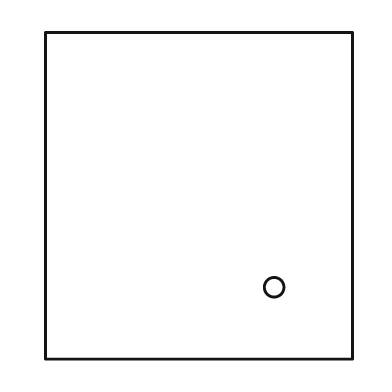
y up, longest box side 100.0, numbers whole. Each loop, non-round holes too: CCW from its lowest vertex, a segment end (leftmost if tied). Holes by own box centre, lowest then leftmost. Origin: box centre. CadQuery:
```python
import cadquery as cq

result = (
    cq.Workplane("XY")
    .moveTo(-47.0, -50.0)
    .lineTo(47.0, -50.0)
    .lineTo(47.0, 50.0)
    .lineTo(-47.0, 50.0)
    .close()
    .moveTo(23.0, -28.0)
    .circle(3.0)
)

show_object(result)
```